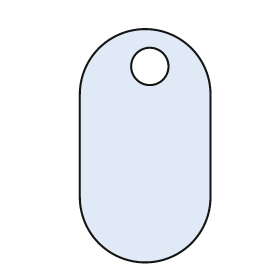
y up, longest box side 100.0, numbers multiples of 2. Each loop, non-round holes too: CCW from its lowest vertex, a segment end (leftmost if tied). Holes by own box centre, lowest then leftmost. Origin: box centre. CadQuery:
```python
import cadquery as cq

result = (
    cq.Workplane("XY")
    .moveTo(-28.0, -22.0)
    .threePointArc((0.0, -50.0), (28.0, -22.0))
    .lineTo(28.0, 22.0)
    .threePointArc((0.0, 50.0), (-28.0, 22.0))
    .close()
    .moveTo(2.0, 34.0)
    .circle(8.0)
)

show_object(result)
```